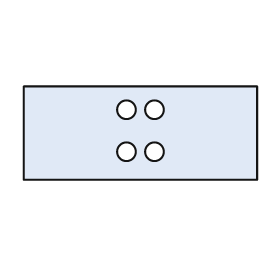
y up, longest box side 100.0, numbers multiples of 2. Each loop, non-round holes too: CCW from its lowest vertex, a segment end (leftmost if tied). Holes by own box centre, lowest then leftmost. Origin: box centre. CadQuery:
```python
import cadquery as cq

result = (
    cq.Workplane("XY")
    .moveTo(-50.0, -20.0)
    .lineTo(50.0, -20.0)
    .lineTo(50.0, 20.0)
    .lineTo(-50.0, 20.0)
    .close()
    .moveTo(-6.0, -8.0)
    .circle(4.0)
    .moveTo(6.0, -8.0)
    .circle(4.0)
    .moveTo(-6.0, 10.0)
    .circle(4.0)
    .moveTo(6.0, 10.0)
    .circle(4.0)
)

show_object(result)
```